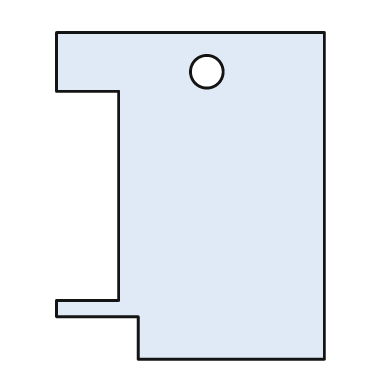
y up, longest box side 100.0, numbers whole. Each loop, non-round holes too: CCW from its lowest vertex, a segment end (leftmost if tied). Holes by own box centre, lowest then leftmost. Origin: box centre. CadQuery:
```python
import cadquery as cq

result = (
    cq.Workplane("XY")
    .moveTo(-16.0, -50.0)
    .lineTo(41.0, -50.0)
    .lineTo(41.0, 50.0)
    .lineTo(-41.0, 50.0)
    .lineTo(-41.0, 32.0)
    .lineTo(-22.0, 32.0)
    .lineTo(-22.0, -32.0)
    .lineTo(-41.0, -32.0)
    .lineTo(-41.0, -37.0)
    .lineTo(-16.0, -37.0)
    .close()
    .moveTo(5.0, 38.0)
    .circle(5.0)
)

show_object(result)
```